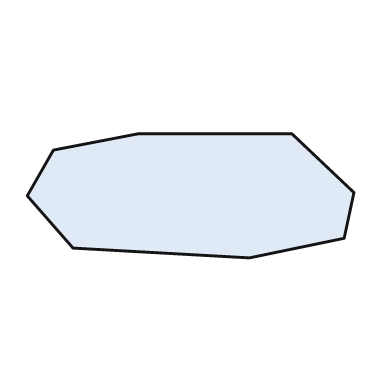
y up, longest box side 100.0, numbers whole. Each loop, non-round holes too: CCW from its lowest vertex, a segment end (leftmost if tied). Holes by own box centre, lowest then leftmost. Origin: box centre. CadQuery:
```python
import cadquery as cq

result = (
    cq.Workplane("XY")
    .moveTo(18.0, -19.0)
    .lineTo(47.0, -13.0)
    .lineTo(50.0, 1.0)
    .lineTo(31.0, 19.0)
    .lineTo(-16.0, 19.0)
    .lineTo(-42.0, 14.0)
    .lineTo(-50.0, 0.0)
    .lineTo(-36.0, -16.0)
    .close()
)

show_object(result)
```